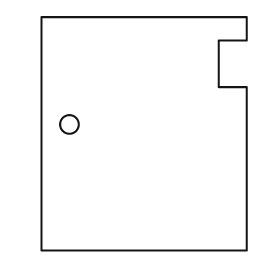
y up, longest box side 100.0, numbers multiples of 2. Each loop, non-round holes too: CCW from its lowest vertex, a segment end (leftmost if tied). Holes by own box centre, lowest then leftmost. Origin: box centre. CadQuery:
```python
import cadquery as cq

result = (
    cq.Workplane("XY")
    .moveTo(-44.0, -50.0)
    .lineTo(44.0, -50.0)
    .lineTo(44.0, 20.0)
    .lineTo(32.0, 20.0)
    .lineTo(32.0, 40.0)
    .lineTo(44.0, 40.0)
    .lineTo(44.0, 50.0)
    .lineTo(-44.0, 50.0)
    .close()
    .moveTo(-32.0, 4.0)
    .circle(4.0)
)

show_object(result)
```